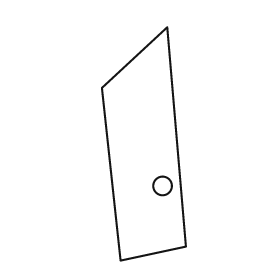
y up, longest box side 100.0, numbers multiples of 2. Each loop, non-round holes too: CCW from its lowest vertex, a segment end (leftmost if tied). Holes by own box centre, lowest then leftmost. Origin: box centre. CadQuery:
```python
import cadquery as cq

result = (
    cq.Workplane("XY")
    .moveTo(-10.0, -50.0)
    .lineTo(18.0, -44.0)
    .lineTo(10.0, 50.0)
    .lineTo(-18.0, 24.0)
    .close()
    .moveTo(8.0, -18.0)
    .circle(4.0)
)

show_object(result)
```